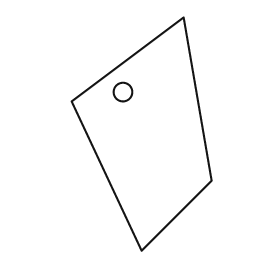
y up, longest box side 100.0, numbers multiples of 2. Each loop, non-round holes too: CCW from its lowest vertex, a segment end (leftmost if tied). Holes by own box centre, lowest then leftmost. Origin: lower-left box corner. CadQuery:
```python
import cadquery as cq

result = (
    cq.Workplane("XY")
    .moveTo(30.0, 0.0)
    .lineTo(60.0, 30.0)
    .lineTo(48.0, 100.0)
    .lineTo(0.0, 64.0)
    .close()
    .moveTo(22.0, 68.0)
    .circle(4.0)
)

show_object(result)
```